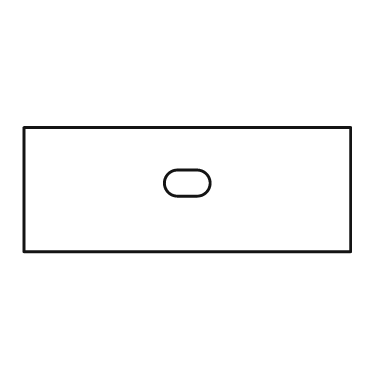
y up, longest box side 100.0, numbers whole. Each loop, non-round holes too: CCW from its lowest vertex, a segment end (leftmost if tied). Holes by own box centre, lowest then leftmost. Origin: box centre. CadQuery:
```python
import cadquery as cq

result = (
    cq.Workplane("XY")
    .moveTo(-50.0, -19.0)
    .lineTo(50.0, -19.0)
    .lineTo(50.0, 19.0)
    .lineTo(-50.0, 19.0)
    .close()
    .moveTo(-3.0, -2.0)
    .lineTo(3.0, -2.0)
    .threePointArc((7.0, 2.0), (3.0, 6.0))
    .lineTo(-3.0, 6.0)
    .threePointArc((-7.0, 2.0), (-3.0, -2.0))
    .close()
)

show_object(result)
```